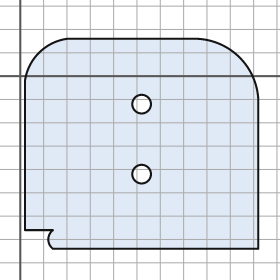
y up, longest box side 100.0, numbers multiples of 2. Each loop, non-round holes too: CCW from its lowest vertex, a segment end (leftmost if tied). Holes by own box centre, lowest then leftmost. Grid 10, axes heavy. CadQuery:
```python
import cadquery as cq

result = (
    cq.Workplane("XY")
    .moveTo(14.0, -74.0)
    .lineTo(102.0, -74.0)
    .lineTo(102.0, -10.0)
    .threePointArc((94.0, 8.0), (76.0, 16.0))
    .lineTo(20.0, 16.0)
    .threePointArc((8.0, 10.0), (2.0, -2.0))
    .lineTo(2.0, -66.0)
    .lineTo(14.0, -66.0)
    .threePointArc((12.0, -70.0), (14.0, -74.0))
    .close()
    .moveTo(52.0, -42.0)
    .circle(4.0)
    .moveTo(52.0, -12.0)
    .circle(4.0)
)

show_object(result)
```